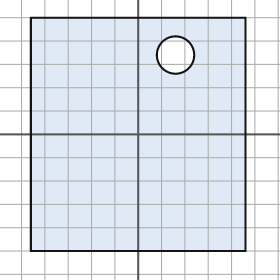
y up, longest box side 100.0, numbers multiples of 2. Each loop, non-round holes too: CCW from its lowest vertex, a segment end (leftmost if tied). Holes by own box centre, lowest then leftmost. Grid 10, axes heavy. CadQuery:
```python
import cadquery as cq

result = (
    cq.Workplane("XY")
    .moveTo(-46.0, -50.0)
    .lineTo(46.0, -50.0)
    .lineTo(46.0, 50.0)
    .lineTo(-46.0, 50.0)
    .close()
    .moveTo(16.0, 34.0)
    .circle(8.0)
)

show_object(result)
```